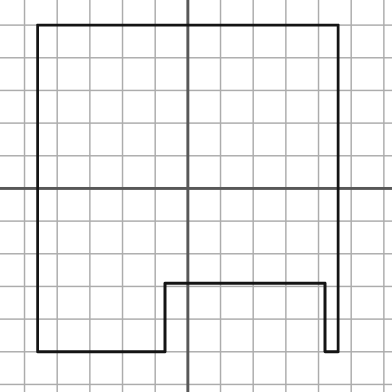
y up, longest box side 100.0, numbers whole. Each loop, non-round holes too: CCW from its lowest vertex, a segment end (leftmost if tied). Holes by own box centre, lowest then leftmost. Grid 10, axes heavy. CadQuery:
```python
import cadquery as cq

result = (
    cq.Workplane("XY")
    .moveTo(-46.0, -50.0)
    .lineTo(-7.0, -50.0)
    .lineTo(-7.0, -29.0)
    .lineTo(42.0, -29.0)
    .lineTo(42.0, -50.0)
    .lineTo(46.0, -50.0)
    .lineTo(46.0, 50.0)
    .lineTo(-46.0, 50.0)
    .close()
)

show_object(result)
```